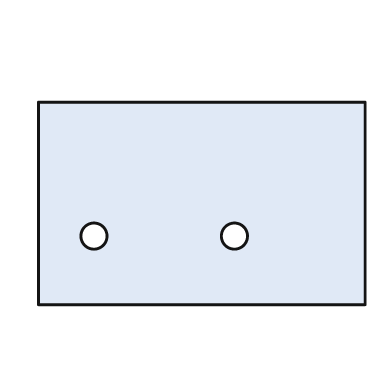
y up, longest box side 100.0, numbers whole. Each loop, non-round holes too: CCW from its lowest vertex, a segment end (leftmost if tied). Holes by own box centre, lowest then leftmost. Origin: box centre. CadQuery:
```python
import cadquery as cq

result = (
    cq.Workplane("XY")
    .moveTo(-50.0, -31.0)
    .lineTo(50.0, -31.0)
    .lineTo(50.0, 31.0)
    .lineTo(-50.0, 31.0)
    .close()
    .moveTo(-33.0, -10.0)
    .circle(4.0)
    .moveTo(10.0, -10.0)
    .circle(4.0)
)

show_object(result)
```